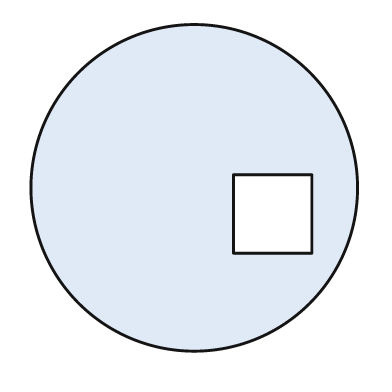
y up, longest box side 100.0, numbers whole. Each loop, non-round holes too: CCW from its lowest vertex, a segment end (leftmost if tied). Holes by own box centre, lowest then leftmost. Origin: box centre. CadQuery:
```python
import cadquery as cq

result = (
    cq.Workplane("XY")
    .moveTo(0.0, 0.0)
    .circle(50.0)
    .moveTo(12.0, -20.0)
    .lineTo(36.0, -20.0)
    .lineTo(36.0, 4.0)
    .lineTo(12.0, 4.0)
    .close()
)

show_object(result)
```